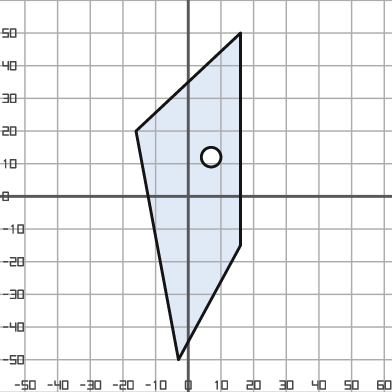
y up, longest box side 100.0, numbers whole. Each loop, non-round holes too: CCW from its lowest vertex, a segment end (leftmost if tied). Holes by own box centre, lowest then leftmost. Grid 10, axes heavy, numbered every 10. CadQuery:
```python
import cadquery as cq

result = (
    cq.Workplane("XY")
    .moveTo(-3.0, -50.0)
    .lineTo(16.0, -15.0)
    .lineTo(16.0, 50.0)
    .lineTo(-16.0, 20.0)
    .close()
    .moveTo(7.0, 12.0)
    .circle(3.0)
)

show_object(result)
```